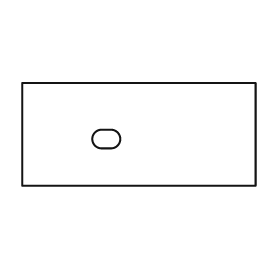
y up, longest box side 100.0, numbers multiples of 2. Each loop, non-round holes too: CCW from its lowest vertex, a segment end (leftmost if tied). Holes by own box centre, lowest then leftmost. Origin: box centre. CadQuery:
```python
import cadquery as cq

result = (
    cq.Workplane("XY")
    .moveTo(-50.0, -22.0)
    .lineTo(50.0, -22.0)
    .lineTo(50.0, 22.0)
    .lineTo(-50.0, 22.0)
    .close()
    .moveTo(-16.0, -6.0)
    .lineTo(-12.0, -6.0)
    .threePointArc((-8.0, -2.0), (-12.0, 2.0))
    .lineTo(-16.0, 2.0)
    .threePointArc((-20.0, -2.0), (-16.0, -6.0))
    .close()
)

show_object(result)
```